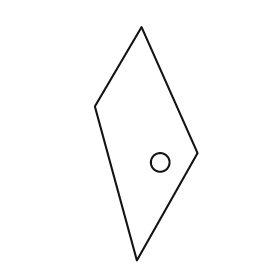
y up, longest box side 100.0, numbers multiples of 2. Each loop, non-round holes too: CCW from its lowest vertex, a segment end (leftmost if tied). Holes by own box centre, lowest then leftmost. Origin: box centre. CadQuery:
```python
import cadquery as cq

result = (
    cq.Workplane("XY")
    .moveTo(-4.0, -50.0)
    .lineTo(22.0, -4.0)
    .lineTo(-2.0, 50.0)
    .lineTo(-22.0, 16.0)
    .close()
    .moveTo(6.0, -8.0)
    .circle(4.0)
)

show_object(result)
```